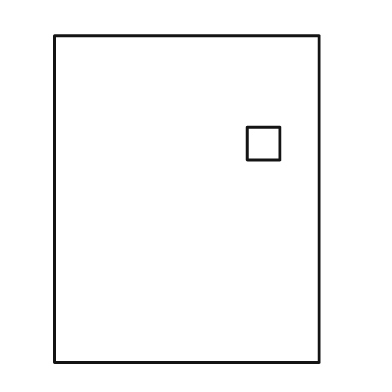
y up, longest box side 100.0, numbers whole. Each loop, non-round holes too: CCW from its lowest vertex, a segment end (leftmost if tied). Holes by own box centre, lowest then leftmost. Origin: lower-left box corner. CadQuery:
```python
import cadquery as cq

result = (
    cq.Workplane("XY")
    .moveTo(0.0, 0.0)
    .lineTo(81.0, 0.0)
    .lineTo(81.0, 100.0)
    .lineTo(0.0, 100.0)
    .close()
    .moveTo(59.0, 62.0)
    .lineTo(69.0, 62.0)
    .lineTo(69.0, 72.0)
    .lineTo(59.0, 72.0)
    .close()
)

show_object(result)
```